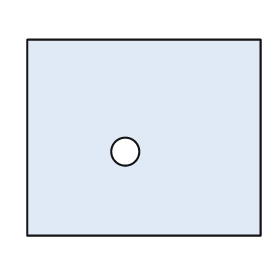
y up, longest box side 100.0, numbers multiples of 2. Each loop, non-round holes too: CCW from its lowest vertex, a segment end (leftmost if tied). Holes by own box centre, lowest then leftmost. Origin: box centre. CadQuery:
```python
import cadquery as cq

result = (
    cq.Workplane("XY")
    .moveTo(-50.0, -42.0)
    .lineTo(50.0, -42.0)
    .lineTo(50.0, 42.0)
    .lineTo(-50.0, 42.0)
    .close()
    .moveTo(-8.0, -6.0)
    .circle(6.0)
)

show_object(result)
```